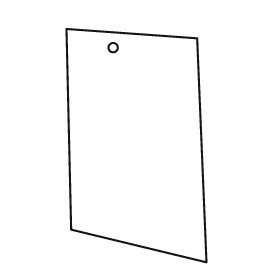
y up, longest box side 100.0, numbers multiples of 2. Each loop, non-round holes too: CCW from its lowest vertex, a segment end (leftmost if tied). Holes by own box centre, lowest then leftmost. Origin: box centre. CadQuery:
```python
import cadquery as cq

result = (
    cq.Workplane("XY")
    .moveTo(30.0, -50.0)
    .lineTo(26.0, 46.0)
    .lineTo(-30.0, 50.0)
    .lineTo(-28.0, -36.0)
    .close()
    .moveTo(-10.0, 42.0)
    .circle(2.0)
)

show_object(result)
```